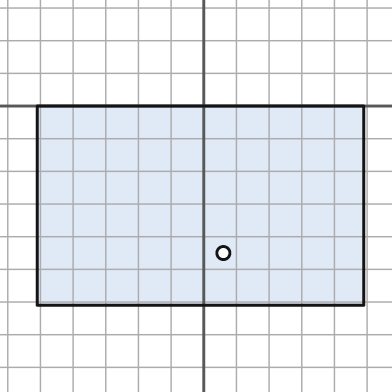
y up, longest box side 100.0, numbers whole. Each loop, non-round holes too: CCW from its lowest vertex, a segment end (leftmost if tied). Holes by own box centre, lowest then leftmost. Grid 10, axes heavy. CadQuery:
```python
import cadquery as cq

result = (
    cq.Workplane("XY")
    .moveTo(-51.0, -61.0)
    .lineTo(49.0, -61.0)
    .lineTo(49.0, 0.0)
    .lineTo(-51.0, 0.0)
    .close()
    .moveTo(6.0, -45.0)
    .circle(2.0)
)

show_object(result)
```